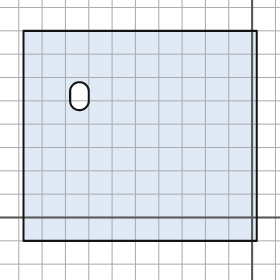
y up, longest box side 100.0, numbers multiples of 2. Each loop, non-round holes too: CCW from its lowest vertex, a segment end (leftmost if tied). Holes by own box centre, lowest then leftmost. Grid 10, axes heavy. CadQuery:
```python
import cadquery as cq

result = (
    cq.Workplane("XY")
    .moveTo(-98.0, -10.0)
    .lineTo(2.0, -10.0)
    .lineTo(2.0, 80.0)
    .lineTo(-98.0, 80.0)
    .close()
    .moveTo(-78.0, 50.0)
    .threePointArc((-74.0, 46.0), (-70.0, 50.0))
    .lineTo(-70.0, 54.0)
    .threePointArc((-74.0, 58.0), (-78.0, 54.0))
    .close()
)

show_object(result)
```